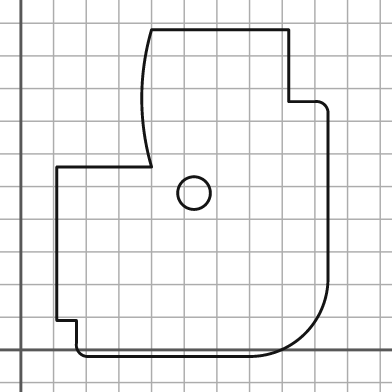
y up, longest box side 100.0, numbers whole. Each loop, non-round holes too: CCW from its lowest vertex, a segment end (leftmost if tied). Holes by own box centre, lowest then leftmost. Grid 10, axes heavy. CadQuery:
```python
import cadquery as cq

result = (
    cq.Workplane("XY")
    .moveTo(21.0, -2.0)
    .lineTo(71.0, -2.0)
    .threePointArc((87.0, 5.0), (94.0, 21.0))
    .lineTo(94.0, 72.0)
    .threePointArc((93.0, 75.0), (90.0, 76.0))
    .lineTo(82.0, 76.0)
    .lineTo(82.0, 98.0)
    .lineTo(40.0, 98.0)
    .threePointArc((37.0, 77.0), (40.0, 56.0))
    .lineTo(11.0, 56.0)
    .lineTo(11.0, 9.0)
    .lineTo(17.0, 9.0)
    .lineTo(17.0, 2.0)
    .threePointArc((18.0, -1.0), (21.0, -2.0))
    .close()
    .moveTo(53.0, 48.0)
    .circle(5.0)
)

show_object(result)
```